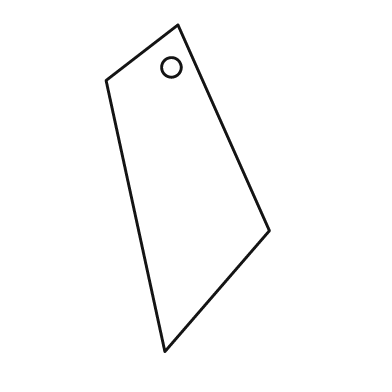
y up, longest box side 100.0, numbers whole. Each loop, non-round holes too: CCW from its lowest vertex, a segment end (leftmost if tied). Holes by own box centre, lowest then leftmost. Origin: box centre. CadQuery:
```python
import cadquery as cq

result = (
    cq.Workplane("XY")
    .moveTo(-7.0, -50.0)
    .lineTo(25.0, -13.0)
    .lineTo(-3.0, 50.0)
    .lineTo(-25.0, 33.0)
    .close()
    .moveTo(-5.0, 37.0)
    .circle(3.0)
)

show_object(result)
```